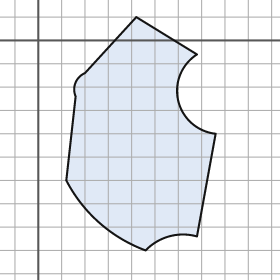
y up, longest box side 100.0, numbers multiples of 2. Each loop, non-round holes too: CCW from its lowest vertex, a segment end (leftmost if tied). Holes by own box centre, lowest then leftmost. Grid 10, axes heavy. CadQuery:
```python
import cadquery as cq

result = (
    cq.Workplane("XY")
    .moveTo(46.0, -90.0)
    .threePointArc((56.0, -84.0), (68.0, -84.0))
    .lineTo(76.0, -40.0)
    .threePointArc((60.0, -26.0), (68.0, -6.0))
    .lineTo(42.0, 10.0)
    .lineTo(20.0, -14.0)
    .threePointArc((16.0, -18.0), (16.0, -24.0))
    .lineTo(12.0, -60.0)
    .threePointArc((26.0, -78.0), (46.0, -90.0))
    .close()
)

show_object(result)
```